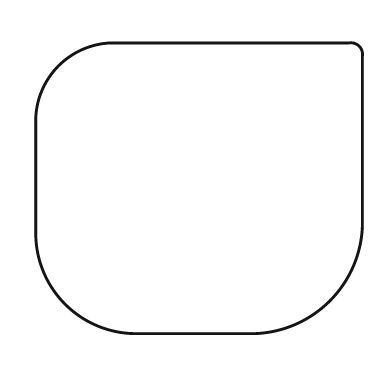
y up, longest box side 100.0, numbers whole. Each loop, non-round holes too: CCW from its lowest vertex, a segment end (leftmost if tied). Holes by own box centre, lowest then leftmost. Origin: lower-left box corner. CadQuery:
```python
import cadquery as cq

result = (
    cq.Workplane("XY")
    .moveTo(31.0, 0.0)
    .lineTo(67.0, 0.0)
    .threePointArc((90.0, 10.0), (100.0, 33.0))
    .lineTo(100.0, 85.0)
    .threePointArc((99.0, 88.0), (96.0, 89.0))
    .lineTo(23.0, 89.0)
    .threePointArc((7.0, 82.0), (0.0, 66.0))
    .lineTo(0.0, 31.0)
    .threePointArc((9.0, 9.0), (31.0, 0.0))
    .close()
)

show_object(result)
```